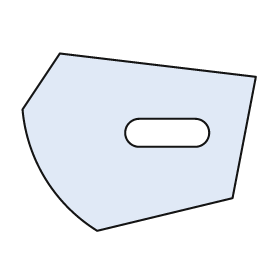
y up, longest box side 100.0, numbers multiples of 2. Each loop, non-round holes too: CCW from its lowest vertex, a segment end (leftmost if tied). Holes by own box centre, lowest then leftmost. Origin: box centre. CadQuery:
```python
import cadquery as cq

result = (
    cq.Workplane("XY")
    .moveTo(-18.0, -38.0)
    .lineTo(40.0, -24.0)
    .lineTo(50.0, 28.0)
    .lineTo(-34.0, 38.0)
    .lineTo(-50.0, 14.0)
    .threePointArc((-40.0, -16.0), (-18.0, -38.0))
    .close()
    .moveTo(0.0, -2.0)
    .lineTo(24.0, -2.0)
    .threePointArc((30.0, 4.0), (24.0, 10.0))
    .lineTo(0.0, 10.0)
    .threePointArc((-6.0, 4.0), (0.0, -2.0))
    .close()
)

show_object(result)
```